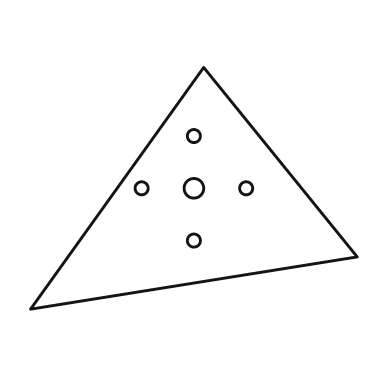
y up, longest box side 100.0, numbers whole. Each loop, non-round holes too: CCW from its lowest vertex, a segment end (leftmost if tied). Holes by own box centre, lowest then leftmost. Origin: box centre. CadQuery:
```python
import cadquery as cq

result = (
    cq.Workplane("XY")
    .moveTo(-50.0, -37.0)
    .lineTo(50.0, -21.0)
    .lineTo(3.0, 37.0)
    .close()
    .moveTo(0.0, -16.0)
    .circle(2.0)
    .moveTo(-16.0, 0.0)
    .circle(2.0)
    .moveTo(0.0, 0.0)
    .circle(3.0)
    .moveTo(16.0, 0.0)
    .circle(2.0)
    .moveTo(0.0, 16.0)
    .circle(2.0)
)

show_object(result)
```